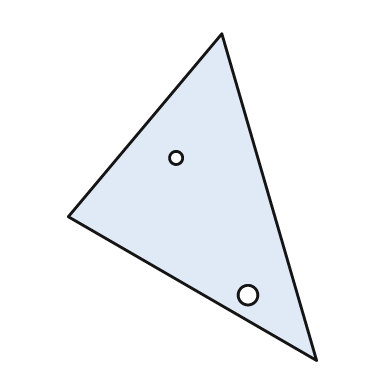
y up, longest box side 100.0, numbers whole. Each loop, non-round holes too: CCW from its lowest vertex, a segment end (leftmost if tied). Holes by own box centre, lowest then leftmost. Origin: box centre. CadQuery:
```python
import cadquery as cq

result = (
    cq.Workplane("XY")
    .moveTo(38.0, -50.0)
    .lineTo(9.0, 50.0)
    .lineTo(-38.0, -6.0)
    .close()
    .moveTo(17.0, -30.0)
    .circle(3.0)
    .moveTo(-5.0, 12.0)
    .circle(2.0)
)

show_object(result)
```